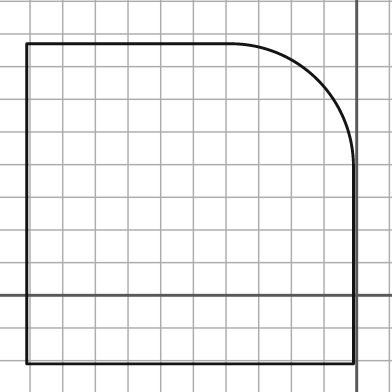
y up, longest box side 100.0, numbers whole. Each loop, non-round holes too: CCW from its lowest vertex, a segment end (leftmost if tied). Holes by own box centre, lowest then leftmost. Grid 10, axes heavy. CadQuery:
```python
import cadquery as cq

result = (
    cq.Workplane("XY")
    .moveTo(-101.0, -21.0)
    .lineTo(-1.0, -21.0)
    .lineTo(-1.0, 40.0)
    .threePointArc((-12.0, 66.0), (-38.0, 77.0))
    .lineTo(-101.0, 77.0)
    .close()
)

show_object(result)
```